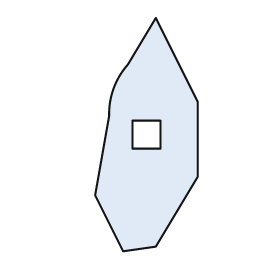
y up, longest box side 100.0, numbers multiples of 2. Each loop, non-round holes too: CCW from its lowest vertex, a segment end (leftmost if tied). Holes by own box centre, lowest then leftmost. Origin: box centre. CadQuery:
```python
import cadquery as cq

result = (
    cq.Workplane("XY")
    .moveTo(-10.0, -50.0)
    .lineTo(4.0, -48.0)
    .lineTo(22.0, -18.0)
    .lineTo(22.0, 14.0)
    .lineTo(4.0, 50.0)
    .lineTo(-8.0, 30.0)
    .threePointArc((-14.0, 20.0), (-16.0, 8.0))
    .lineTo(-22.0, -26.0)
    .close()
    .moveTo(-6.0, -6.0)
    .lineTo(6.0, -6.0)
    .lineTo(6.0, 6.0)
    .lineTo(-6.0, 6.0)
    .close()
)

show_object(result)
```